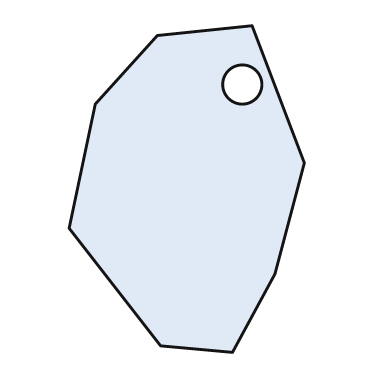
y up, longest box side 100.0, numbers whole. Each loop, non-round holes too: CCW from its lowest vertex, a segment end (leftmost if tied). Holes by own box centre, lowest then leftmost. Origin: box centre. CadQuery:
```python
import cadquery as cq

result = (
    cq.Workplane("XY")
    .moveTo(14.0, -50.0)
    .lineTo(27.0, -26.0)
    .lineTo(36.0, 8.0)
    .lineTo(20.0, 50.0)
    .lineTo(-9.0, 47.0)
    .lineTo(-28.0, 26.0)
    .lineTo(-36.0, -12.0)
    .lineTo(-8.0, -48.0)
    .close()
    .moveTo(17.0, 32.0)
    .circle(6.0)
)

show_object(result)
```